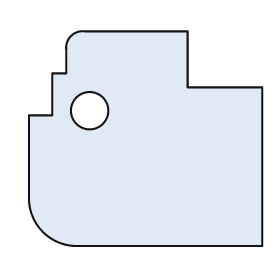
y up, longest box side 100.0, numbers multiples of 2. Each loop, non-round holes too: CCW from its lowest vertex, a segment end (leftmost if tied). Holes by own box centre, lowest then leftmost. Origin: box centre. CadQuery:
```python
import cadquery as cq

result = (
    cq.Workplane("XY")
    .moveTo(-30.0, -46.0)
    .lineTo(50.0, -46.0)
    .lineTo(50.0, 22.0)
    .lineTo(18.0, 22.0)
    .lineTo(18.0, 46.0)
    .lineTo(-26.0, 46.0)
    .threePointArc((-32.0, 44.0), (-34.0, 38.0))
    .lineTo(-34.0, 28.0)
    .lineTo(-40.0, 28.0)
    .lineTo(-40.0, 10.0)
    .lineTo(-50.0, 10.0)
    .lineTo(-50.0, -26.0)
    .threePointArc((-44.0, -40.0), (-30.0, -46.0))
    .close()
    .moveTo(-24.0, 12.0)
    .circle(8.0)
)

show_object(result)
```